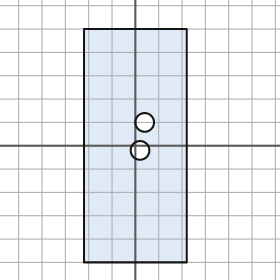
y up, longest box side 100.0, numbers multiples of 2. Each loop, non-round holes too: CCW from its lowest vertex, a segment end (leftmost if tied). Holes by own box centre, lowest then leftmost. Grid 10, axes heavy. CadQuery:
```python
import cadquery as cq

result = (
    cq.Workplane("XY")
    .moveTo(-22.0, -50.0)
    .lineTo(22.0, -50.0)
    .lineTo(22.0, 50.0)
    .lineTo(-22.0, 50.0)
    .close()
    .moveTo(2.0, -2.0)
    .circle(4.0)
    .moveTo(4.0, 10.0)
    .circle(4.0)
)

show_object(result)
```